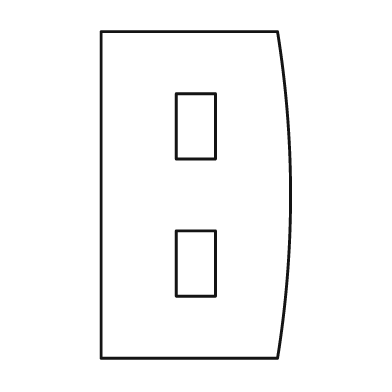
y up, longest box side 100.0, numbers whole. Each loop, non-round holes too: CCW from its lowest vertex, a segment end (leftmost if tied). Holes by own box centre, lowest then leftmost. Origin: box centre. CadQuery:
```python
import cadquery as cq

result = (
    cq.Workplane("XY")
    .moveTo(-29.0, -50.0)
    .lineTo(25.0, -50.0)
    .threePointArc((29.0, 0.0), (25.0, 50.0))
    .lineTo(-29.0, 50.0)
    .close()
    .moveTo(-6.0, -31.0)
    .lineTo(6.0, -31.0)
    .lineTo(6.0, -11.0)
    .lineTo(-6.0, -11.0)
    .close()
    .moveTo(-6.0, 11.0)
    .lineTo(6.0, 11.0)
    .lineTo(6.0, 31.0)
    .lineTo(-6.0, 31.0)
    .close()
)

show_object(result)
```